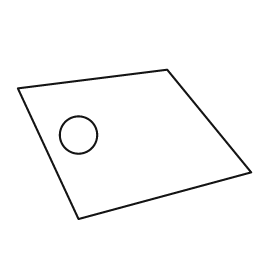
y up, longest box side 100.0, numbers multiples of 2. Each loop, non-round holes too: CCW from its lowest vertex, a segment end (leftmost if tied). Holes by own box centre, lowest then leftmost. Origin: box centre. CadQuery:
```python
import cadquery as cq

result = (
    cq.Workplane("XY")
    .moveTo(-24.0, -32.0)
    .lineTo(50.0, -12.0)
    .lineTo(14.0, 32.0)
    .lineTo(-50.0, 24.0)
    .close()
    .moveTo(-24.0, 4.0)
    .circle(8.0)
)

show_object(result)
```